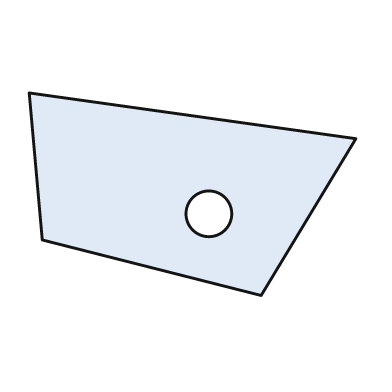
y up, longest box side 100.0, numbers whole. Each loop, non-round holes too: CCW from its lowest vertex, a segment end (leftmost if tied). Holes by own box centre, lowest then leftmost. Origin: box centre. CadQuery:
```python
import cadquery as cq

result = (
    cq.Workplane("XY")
    .moveTo(21.0, -31.0)
    .lineTo(50.0, 17.0)
    .lineTo(-50.0, 31.0)
    .lineTo(-46.0, -14.0)
    .close()
    .moveTo(5.0, -6.0)
    .circle(7.0)
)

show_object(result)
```